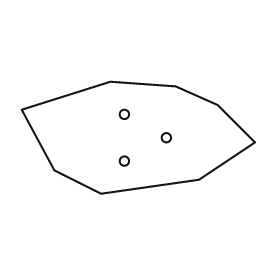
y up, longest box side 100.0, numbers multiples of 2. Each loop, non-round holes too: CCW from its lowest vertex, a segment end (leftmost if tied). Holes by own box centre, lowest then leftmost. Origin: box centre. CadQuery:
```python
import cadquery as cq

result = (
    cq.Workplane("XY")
    .moveTo(-16.0, -24.0)
    .lineTo(26.0, -18.0)
    .lineTo(50.0, -2.0)
    .lineTo(34.0, 14.0)
    .lineTo(16.0, 22.0)
    .lineTo(-12.0, 24.0)
    .lineTo(-50.0, 12.0)
    .lineTo(-36.0, -14.0)
    .close()
    .moveTo(-6.0, -10.0)
    .circle(2.0)
    .moveTo(12.0, 0.0)
    .circle(2.0)
    .moveTo(-6.0, 10.0)
    .circle(2.0)
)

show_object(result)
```